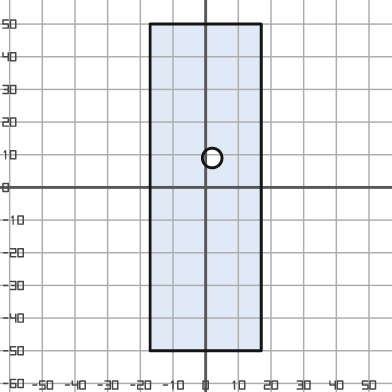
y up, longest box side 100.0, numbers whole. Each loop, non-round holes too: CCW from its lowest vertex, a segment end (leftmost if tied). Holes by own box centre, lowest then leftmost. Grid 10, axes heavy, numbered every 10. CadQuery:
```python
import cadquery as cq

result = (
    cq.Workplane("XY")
    .moveTo(-17.0, -50.0)
    .lineTo(17.0, -50.0)
    .lineTo(17.0, 50.0)
    .lineTo(-17.0, 50.0)
    .close()
    .moveTo(2.0, 9.0)
    .circle(3.0)
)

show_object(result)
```